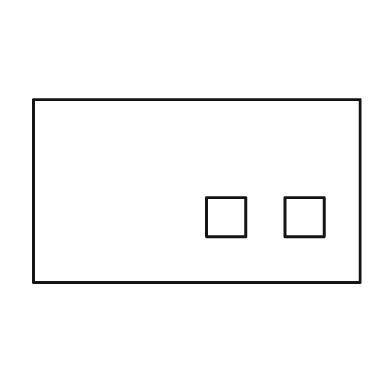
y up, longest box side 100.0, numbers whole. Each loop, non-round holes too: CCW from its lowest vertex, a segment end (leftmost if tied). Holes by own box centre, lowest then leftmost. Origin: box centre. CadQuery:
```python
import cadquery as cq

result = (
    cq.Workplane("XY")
    .moveTo(-50.0, -28.0)
    .lineTo(50.0, -28.0)
    .lineTo(50.0, 28.0)
    .lineTo(-50.0, 28.0)
    .close()
    .moveTo(3.0, -14.0)
    .lineTo(15.0, -14.0)
    .lineTo(15.0, -2.0)
    .lineTo(3.0, -2.0)
    .close()
    .moveTo(27.0, -14.0)
    .lineTo(39.0, -14.0)
    .lineTo(39.0, -2.0)
    .lineTo(27.0, -2.0)
    .close()
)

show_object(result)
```